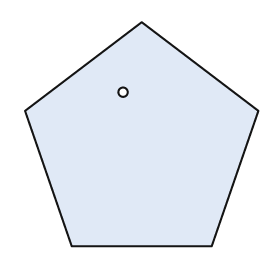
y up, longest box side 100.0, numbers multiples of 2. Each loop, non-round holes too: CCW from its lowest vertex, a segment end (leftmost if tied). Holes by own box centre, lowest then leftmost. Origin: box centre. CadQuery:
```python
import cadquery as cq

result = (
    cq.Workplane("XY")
    .moveTo(-30.0, -48.0)
    .lineTo(30.0, -48.0)
    .lineTo(50.0, 10.0)
    .lineTo(0.0, 48.0)
    .lineTo(-50.0, 10.0)
    .close()
    .moveTo(-8.0, 18.0)
    .circle(2.0)
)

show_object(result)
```